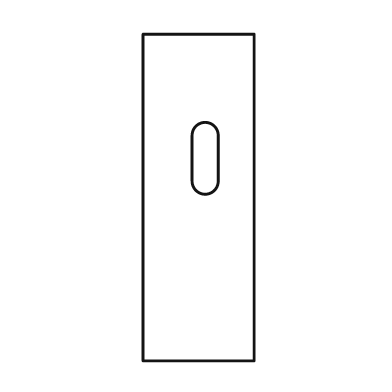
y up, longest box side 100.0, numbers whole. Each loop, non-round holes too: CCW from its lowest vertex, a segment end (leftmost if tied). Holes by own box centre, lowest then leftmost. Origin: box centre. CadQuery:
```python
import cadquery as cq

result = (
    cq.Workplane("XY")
    .moveTo(-17.0, -50.0)
    .lineTo(17.0, -50.0)
    .lineTo(17.0, 50.0)
    .lineTo(-17.0, 50.0)
    .close()
    .moveTo(-2.0, 5.0)
    .threePointArc((2.0, 1.0), (6.0, 5.0))
    .lineTo(6.0, 19.0)
    .threePointArc((2.0, 23.0), (-2.0, 19.0))
    .close()
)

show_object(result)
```